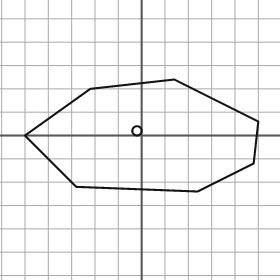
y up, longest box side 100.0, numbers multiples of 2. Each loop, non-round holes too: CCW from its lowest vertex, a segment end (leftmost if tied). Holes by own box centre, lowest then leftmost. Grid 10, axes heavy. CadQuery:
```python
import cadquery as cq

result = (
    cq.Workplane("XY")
    .moveTo(24.0, -24.0)
    .lineTo(48.0, -12.0)
    .lineTo(50.0, 6.0)
    .lineTo(14.0, 24.0)
    .lineTo(-22.0, 20.0)
    .lineTo(-50.0, 0.0)
    .lineTo(-28.0, -22.0)
    .close()
    .moveTo(-2.0, 2.0)
    .circle(2.0)
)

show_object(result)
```